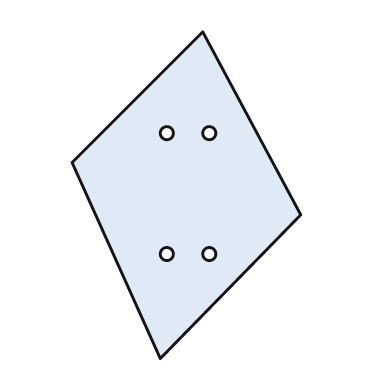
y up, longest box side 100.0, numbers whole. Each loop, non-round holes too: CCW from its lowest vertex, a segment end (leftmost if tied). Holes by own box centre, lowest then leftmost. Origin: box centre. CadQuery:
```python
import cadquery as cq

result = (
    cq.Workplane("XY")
    .moveTo(-8.0, -50.0)
    .lineTo(35.0, -6.0)
    .lineTo(5.0, 50.0)
    .lineTo(-35.0, 10.0)
    .close()
    .moveTo(-6.0, -18.0)
    .circle(2.0)
    .moveTo(7.0, -18.0)
    .circle(2.0)
    .moveTo(-6.0, 19.0)
    .circle(2.0)
    .moveTo(7.0, 19.0)
    .circle(2.0)
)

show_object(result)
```